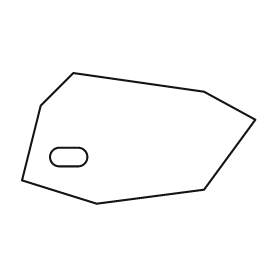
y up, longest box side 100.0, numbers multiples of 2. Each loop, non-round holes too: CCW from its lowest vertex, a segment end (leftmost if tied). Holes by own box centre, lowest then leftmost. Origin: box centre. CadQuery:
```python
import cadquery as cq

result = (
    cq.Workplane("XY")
    .moveTo(-18.0, -28.0)
    .lineTo(28.0, -22.0)
    .lineTo(50.0, 8.0)
    .lineTo(28.0, 20.0)
    .lineTo(-28.0, 28.0)
    .lineTo(-42.0, 14.0)
    .lineTo(-50.0, -18.0)
    .close()
    .moveTo(-34.0, -12.0)
    .lineTo(-26.0, -12.0)
    .threePointArc((-22.0, -8.0), (-26.0, -4.0))
    .lineTo(-34.0, -4.0)
    .threePointArc((-38.0, -8.0), (-34.0, -12.0))
    .close()
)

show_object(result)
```